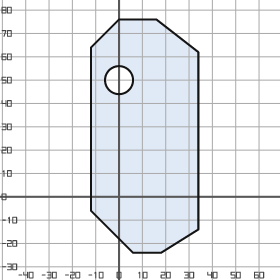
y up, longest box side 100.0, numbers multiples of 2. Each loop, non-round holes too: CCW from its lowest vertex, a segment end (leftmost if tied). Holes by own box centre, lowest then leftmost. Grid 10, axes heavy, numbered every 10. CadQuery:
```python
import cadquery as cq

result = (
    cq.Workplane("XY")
    .moveTo(6.0, -24.0)
    .lineTo(18.0, -24.0)
    .lineTo(34.0, -14.0)
    .lineTo(34.0, 62.0)
    .lineTo(16.0, 76.0)
    .lineTo(0.0, 76.0)
    .lineTo(-12.0, 64.0)
    .lineTo(-12.0, -6.0)
    .close()
    .moveTo(0.0, 50.0)
    .circle(6.0)
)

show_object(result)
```